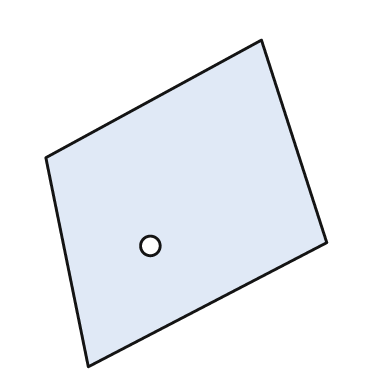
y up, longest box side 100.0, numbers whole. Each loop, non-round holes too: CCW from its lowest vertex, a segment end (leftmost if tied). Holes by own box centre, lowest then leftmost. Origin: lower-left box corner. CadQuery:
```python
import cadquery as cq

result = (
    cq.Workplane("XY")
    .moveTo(13.0, 0.0)
    .lineTo(86.0, 38.0)
    .lineTo(66.0, 100.0)
    .lineTo(0.0, 64.0)
    .close()
    .moveTo(32.0, 37.0)
    .circle(3.0)
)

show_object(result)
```